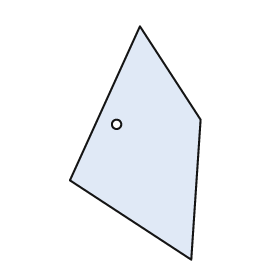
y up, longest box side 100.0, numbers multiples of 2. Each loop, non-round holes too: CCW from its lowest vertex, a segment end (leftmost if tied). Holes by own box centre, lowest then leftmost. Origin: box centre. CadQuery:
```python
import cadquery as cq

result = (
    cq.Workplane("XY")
    .moveTo(24.0, -50.0)
    .lineTo(28.0, 10.0)
    .lineTo(2.0, 50.0)
    .lineTo(-28.0, -16.0)
    .close()
    .moveTo(-8.0, 8.0)
    .circle(2.0)
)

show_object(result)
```